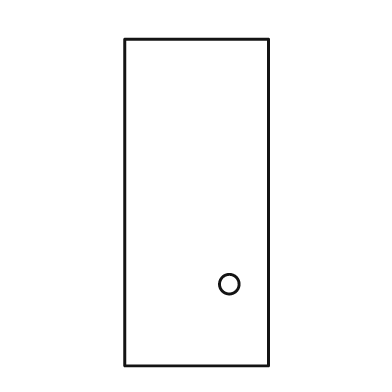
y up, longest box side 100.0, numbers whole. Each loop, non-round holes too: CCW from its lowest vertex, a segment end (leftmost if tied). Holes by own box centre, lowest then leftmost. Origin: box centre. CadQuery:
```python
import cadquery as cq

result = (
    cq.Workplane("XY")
    .moveTo(-22.0, -50.0)
    .lineTo(22.0, -50.0)
    .lineTo(22.0, 50.0)
    .lineTo(-22.0, 50.0)
    .close()
    .moveTo(10.0, -25.0)
    .circle(3.0)
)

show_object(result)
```